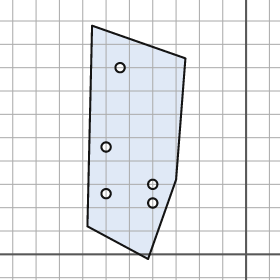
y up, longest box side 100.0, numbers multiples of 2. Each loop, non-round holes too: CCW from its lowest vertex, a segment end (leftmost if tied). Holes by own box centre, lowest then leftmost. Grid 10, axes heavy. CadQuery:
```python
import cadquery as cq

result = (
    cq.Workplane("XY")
    .moveTo(-42.0, -2.0)
    .lineTo(-30.0, 32.0)
    .lineTo(-26.0, 84.0)
    .lineTo(-66.0, 98.0)
    .lineTo(-68.0, 12.0)
    .close()
    .moveTo(-40.0, 22.0)
    .circle(2.0)
    .moveTo(-60.0, 26.0)
    .circle(2.0)
    .moveTo(-40.0, 30.0)
    .circle(2.0)
    .moveTo(-60.0, 46.0)
    .circle(2.0)
    .moveTo(-54.0, 80.0)
    .circle(2.0)
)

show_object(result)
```